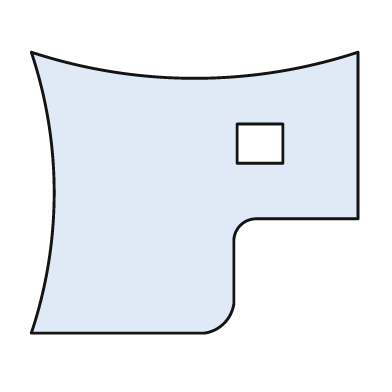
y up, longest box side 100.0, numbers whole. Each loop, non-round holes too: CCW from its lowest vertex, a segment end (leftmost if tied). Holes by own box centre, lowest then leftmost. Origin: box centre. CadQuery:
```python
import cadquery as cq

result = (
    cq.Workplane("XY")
    .moveTo(-50.0, -43.0)
    .lineTo(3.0, -43.0)
    .threePointArc((9.0, -40.0), (12.0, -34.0))
    .lineTo(12.0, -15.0)
    .threePointArc((14.0, -10.0), (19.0, -8.0))
    .lineTo(50.0, -8.0)
    .lineTo(50.0, 43.0)
    .threePointArc((0.0, 35.0), (-50.0, 43.0))
    .threePointArc((-43.0, 0.0), (-50.0, -43.0))
    .close()
    .moveTo(13.0, 9.0)
    .lineTo(27.0, 9.0)
    .lineTo(27.0, 21.0)
    .lineTo(13.0, 21.0)
    .close()
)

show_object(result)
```